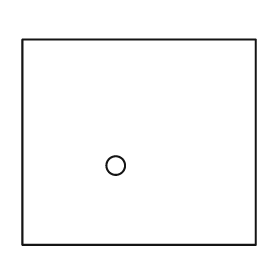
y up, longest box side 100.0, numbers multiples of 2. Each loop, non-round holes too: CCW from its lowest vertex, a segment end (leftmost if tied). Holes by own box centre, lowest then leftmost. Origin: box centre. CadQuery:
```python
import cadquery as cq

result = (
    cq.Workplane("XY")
    .moveTo(-50.0, -44.0)
    .lineTo(50.0, -44.0)
    .lineTo(50.0, 44.0)
    .lineTo(-50.0, 44.0)
    .close()
    .moveTo(-10.0, -10.0)
    .circle(4.0)
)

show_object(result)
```